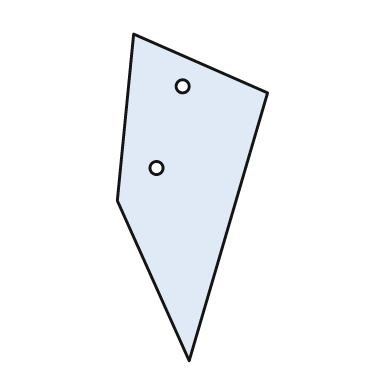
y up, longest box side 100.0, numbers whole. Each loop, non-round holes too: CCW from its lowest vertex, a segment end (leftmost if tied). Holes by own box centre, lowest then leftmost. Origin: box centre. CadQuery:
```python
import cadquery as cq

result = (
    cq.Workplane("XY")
    .moveTo(-1.0, -50.0)
    .lineTo(23.0, 32.0)
    .lineTo(-18.0, 50.0)
    .lineTo(-23.0, -1.0)
    .close()
    .moveTo(-11.0, 9.0)
    .circle(2.0)
    .moveTo(-3.0, 34.0)
    .circle(2.0)
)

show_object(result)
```